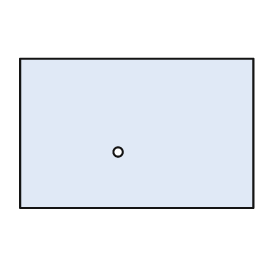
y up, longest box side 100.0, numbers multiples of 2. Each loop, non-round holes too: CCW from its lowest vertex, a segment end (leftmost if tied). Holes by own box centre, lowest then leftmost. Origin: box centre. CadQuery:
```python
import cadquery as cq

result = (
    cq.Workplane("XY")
    .moveTo(-50.0, -32.0)
    .lineTo(50.0, -32.0)
    .lineTo(50.0, 32.0)
    .lineTo(-50.0, 32.0)
    .close()
    .moveTo(-8.0, -8.0)
    .circle(2.0)
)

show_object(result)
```